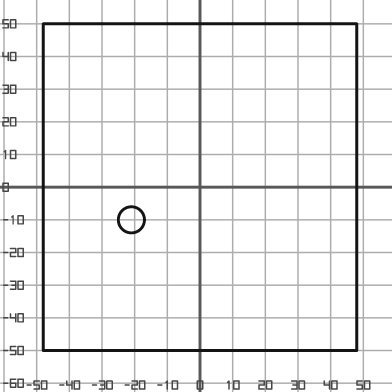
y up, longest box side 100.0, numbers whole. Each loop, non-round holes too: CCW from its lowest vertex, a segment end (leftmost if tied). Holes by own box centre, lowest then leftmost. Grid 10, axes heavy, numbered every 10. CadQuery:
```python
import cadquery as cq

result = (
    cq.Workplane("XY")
    .moveTo(-48.0, -50.0)
    .lineTo(48.0, -50.0)
    .lineTo(48.0, 50.0)
    .lineTo(-48.0, 50.0)
    .close()
    .moveTo(-21.0, -10.0)
    .circle(4.0)
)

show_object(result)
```